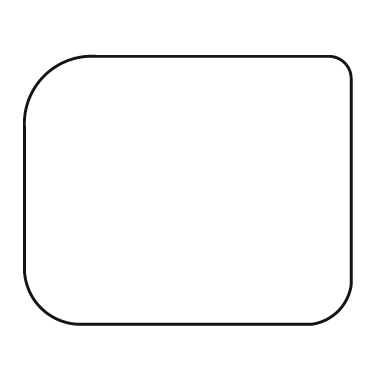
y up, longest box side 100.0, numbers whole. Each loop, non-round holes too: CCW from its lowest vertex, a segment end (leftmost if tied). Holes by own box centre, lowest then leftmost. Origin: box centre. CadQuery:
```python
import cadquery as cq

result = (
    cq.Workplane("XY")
    .moveTo(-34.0, -41.0)
    .lineTo(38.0, -41.0)
    .threePointArc((46.0, -37.0), (50.0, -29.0))
    .lineTo(50.0, 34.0)
    .threePointArc((48.0, 39.0), (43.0, 41.0))
    .lineTo(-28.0, 41.0)
    .threePointArc((-44.0, 35.0), (-50.0, 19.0))
    .lineTo(-50.0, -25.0)
    .threePointArc((-45.0, -36.0), (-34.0, -41.0))
    .close()
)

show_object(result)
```